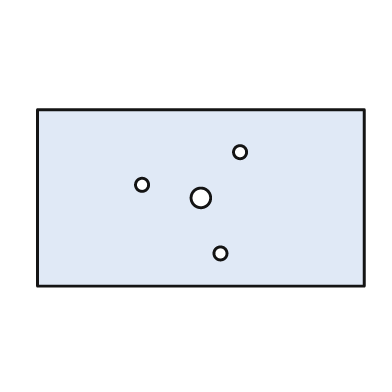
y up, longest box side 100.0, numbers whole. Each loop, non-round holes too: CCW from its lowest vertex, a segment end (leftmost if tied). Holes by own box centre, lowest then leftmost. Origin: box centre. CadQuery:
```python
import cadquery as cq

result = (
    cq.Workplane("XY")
    .moveTo(-50.0, -27.0)
    .lineTo(50.0, -27.0)
    .lineTo(50.0, 27.0)
    .lineTo(-50.0, 27.0)
    .close()
    .moveTo(6.0, -17.0)
    .circle(2.0)
    .moveTo(0.0, 0.0)
    .circle(3.0)
    .moveTo(-18.0, 4.0)
    .circle(2.0)
    .moveTo(12.0, 14.0)
    .circle(2.0)
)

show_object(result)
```